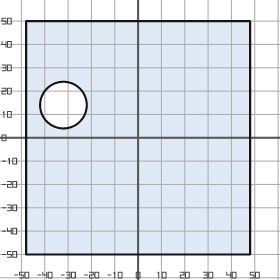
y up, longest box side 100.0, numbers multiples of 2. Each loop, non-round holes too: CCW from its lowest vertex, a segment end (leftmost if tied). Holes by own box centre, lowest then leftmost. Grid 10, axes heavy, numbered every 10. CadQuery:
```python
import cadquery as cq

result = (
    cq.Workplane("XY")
    .moveTo(-48.0, -50.0)
    .lineTo(48.0, -50.0)
    .lineTo(48.0, 50.0)
    .lineTo(-48.0, 50.0)
    .close()
    .moveTo(-32.0, 14.0)
    .circle(10.0)
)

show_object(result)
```